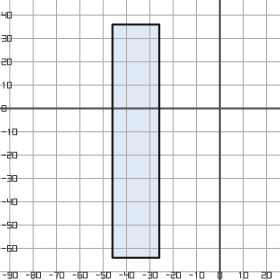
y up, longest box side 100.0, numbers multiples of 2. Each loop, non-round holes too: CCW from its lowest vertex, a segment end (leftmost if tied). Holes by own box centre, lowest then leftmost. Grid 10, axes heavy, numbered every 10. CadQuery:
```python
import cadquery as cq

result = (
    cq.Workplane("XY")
    .moveTo(-46.0, -64.0)
    .lineTo(-26.0, -64.0)
    .lineTo(-26.0, 36.0)
    .lineTo(-46.0, 36.0)
    .close()
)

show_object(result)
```